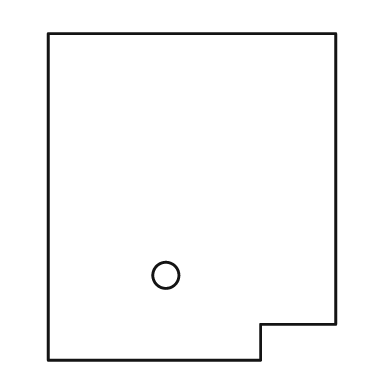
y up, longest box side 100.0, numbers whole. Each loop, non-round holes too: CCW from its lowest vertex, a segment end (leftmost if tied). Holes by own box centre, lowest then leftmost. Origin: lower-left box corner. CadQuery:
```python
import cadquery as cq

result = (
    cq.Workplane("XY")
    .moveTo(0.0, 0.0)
    .lineTo(65.0, 0.0)
    .lineTo(65.0, 11.0)
    .lineTo(88.0, 11.0)
    .lineTo(88.0, 100.0)
    .lineTo(0.0, 100.0)
    .close()
    .moveTo(36.0, 26.0)
    .circle(4.0)
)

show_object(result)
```